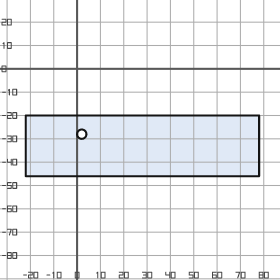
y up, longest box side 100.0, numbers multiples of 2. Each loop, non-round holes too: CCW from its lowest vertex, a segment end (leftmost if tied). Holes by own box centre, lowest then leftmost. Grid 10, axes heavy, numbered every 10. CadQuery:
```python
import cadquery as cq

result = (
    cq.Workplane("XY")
    .moveTo(-22.0, -46.0)
    .lineTo(78.0, -46.0)
    .lineTo(78.0, -20.0)
    .lineTo(-22.0, -20.0)
    .close()
    .moveTo(2.0, -28.0)
    .circle(2.0)
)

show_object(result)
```